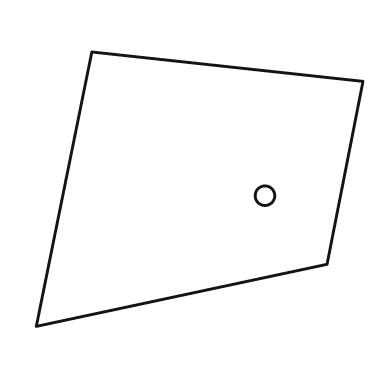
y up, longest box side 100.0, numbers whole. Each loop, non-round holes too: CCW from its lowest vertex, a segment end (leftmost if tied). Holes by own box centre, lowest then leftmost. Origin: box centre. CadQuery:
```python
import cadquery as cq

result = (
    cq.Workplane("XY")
    .moveTo(-50.0, -42.0)
    .lineTo(39.0, -23.0)
    .lineTo(50.0, 33.0)
    .lineTo(-33.0, 42.0)
    .close()
    .moveTo(20.0, -2.0)
    .circle(3.0)
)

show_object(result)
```